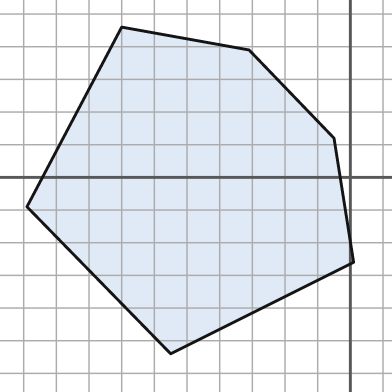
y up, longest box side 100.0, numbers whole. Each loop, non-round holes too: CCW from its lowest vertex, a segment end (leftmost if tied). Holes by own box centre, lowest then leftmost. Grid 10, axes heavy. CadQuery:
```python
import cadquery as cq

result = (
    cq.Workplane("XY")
    .moveTo(-55.0, -54.0)
    .lineTo(1.0, -26.0)
    .lineTo(-5.0, 12.0)
    .lineTo(-31.0, 39.0)
    .lineTo(-70.0, 46.0)
    .lineTo(-99.0, -9.0)
    .close()
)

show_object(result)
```